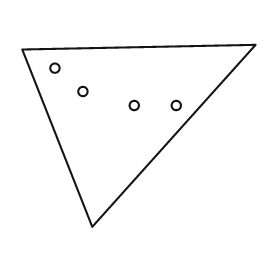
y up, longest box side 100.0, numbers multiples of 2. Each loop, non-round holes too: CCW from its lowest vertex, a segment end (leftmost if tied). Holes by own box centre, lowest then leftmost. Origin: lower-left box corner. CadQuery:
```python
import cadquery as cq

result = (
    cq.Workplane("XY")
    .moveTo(30.0, 0.0)
    .lineTo(100.0, 78.0)
    .lineTo(0.0, 76.0)
    .close()
    .moveTo(48.0, 52.0)
    .circle(2.0)
    .moveTo(66.0, 52.0)
    .circle(2.0)
    .moveTo(26.0, 58.0)
    .circle(2.0)
    .moveTo(14.0, 68.0)
    .circle(2.0)
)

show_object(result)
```